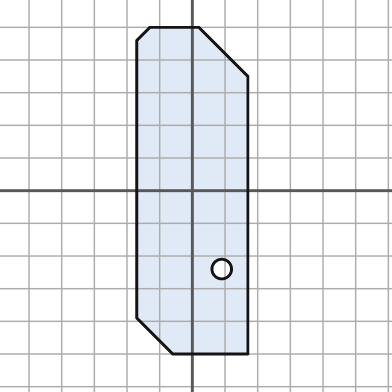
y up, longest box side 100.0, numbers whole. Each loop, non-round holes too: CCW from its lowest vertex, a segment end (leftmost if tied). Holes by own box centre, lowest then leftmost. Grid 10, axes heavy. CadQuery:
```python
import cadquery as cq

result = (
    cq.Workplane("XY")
    .moveTo(-6.0, -50.0)
    .lineTo(17.0, -50.0)
    .lineTo(17.0, 35.0)
    .lineTo(2.0, 50.0)
    .lineTo(-13.0, 50.0)
    .lineTo(-17.0, 46.0)
    .lineTo(-17.0, -39.0)
    .close()
    .moveTo(9.0, -24.0)
    .circle(3.0)
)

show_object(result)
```